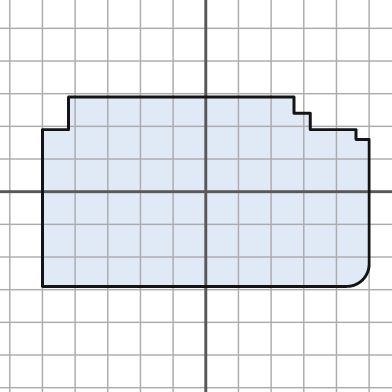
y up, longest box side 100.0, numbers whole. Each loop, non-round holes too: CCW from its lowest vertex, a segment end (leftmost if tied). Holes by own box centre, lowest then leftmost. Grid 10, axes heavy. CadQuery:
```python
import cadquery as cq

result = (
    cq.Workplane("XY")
    .moveTo(-50.0, -29.0)
    .lineTo(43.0, -29.0)
    .threePointArc((48.0, -27.0), (50.0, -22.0))
    .lineTo(50.0, 16.0)
    .lineTo(46.0, 16.0)
    .lineTo(46.0, 19.0)
    .lineTo(32.0, 19.0)
    .lineTo(32.0, 24.0)
    .lineTo(27.0, 24.0)
    .lineTo(27.0, 29.0)
    .lineTo(-42.0, 29.0)
    .lineTo(-42.0, 19.0)
    .lineTo(-50.0, 19.0)
    .close()
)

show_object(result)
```